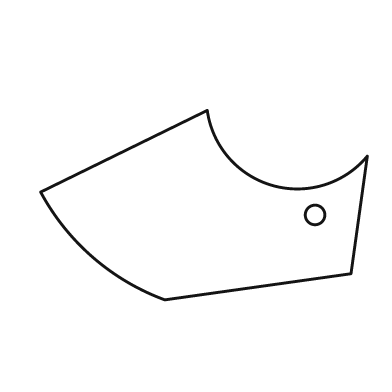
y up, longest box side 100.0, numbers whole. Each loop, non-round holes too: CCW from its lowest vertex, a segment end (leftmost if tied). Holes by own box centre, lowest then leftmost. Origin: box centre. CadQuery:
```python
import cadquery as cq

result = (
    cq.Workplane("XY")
    .moveTo(-12.0, -29.0)
    .lineTo(45.0, -21.0)
    .lineTo(50.0, 15.0)
    .threePointArc((21.0, 6.0), (1.0, 29.0))
    .lineTo(-50.0, 4.0)
    .threePointArc((-34.0, -16.0), (-12.0, -29.0))
    .close()
    .moveTo(34.0, -3.0)
    .circle(3.0)
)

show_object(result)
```